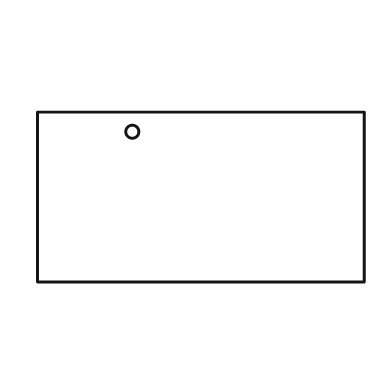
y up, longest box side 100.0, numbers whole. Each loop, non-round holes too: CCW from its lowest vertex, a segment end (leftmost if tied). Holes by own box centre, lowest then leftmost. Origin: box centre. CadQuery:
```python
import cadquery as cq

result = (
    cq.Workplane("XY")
    .moveTo(-50.0, -26.0)
    .lineTo(50.0, -26.0)
    .lineTo(50.0, 26.0)
    .lineTo(-50.0, 26.0)
    .close()
    .moveTo(-21.0, 20.0)
    .circle(2.0)
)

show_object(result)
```